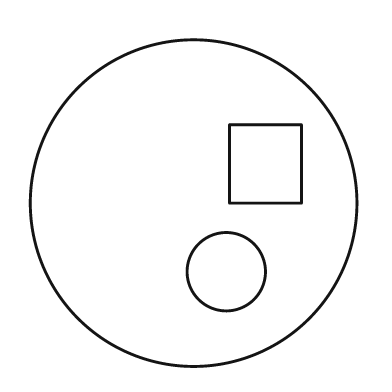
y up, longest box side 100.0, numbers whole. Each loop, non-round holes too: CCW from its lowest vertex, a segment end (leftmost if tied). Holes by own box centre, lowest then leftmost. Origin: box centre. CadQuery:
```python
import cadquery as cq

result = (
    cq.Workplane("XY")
    .moveTo(0.0, 0.0)
    .circle(50.0)
    .moveTo(10.0, -21.0)
    .circle(12.0)
    .moveTo(11.0, 0.0)
    .lineTo(33.0, 0.0)
    .lineTo(33.0, 24.0)
    .lineTo(11.0, 24.0)
    .close()
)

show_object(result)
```